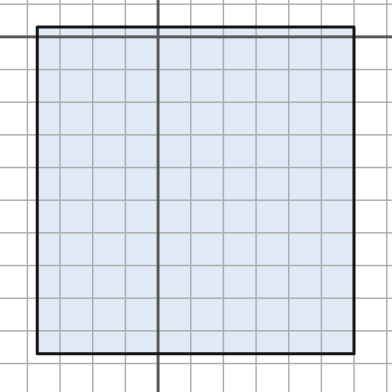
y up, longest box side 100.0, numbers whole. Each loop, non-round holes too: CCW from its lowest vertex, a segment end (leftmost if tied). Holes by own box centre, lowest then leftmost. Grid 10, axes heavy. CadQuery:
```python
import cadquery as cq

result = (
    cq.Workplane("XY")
    .moveTo(-37.0, -97.0)
    .lineTo(60.0, -97.0)
    .lineTo(60.0, 3.0)
    .lineTo(-37.0, 3.0)
    .close()
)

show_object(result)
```